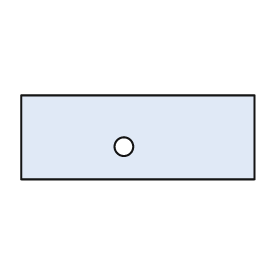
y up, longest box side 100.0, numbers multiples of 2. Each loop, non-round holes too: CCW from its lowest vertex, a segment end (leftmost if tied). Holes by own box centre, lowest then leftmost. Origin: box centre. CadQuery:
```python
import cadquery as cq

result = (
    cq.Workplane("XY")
    .moveTo(-50.0, -18.0)
    .lineTo(50.0, -18.0)
    .lineTo(50.0, 18.0)
    .lineTo(-50.0, 18.0)
    .close()
    .moveTo(-6.0, -4.0)
    .circle(4.0)
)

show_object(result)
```